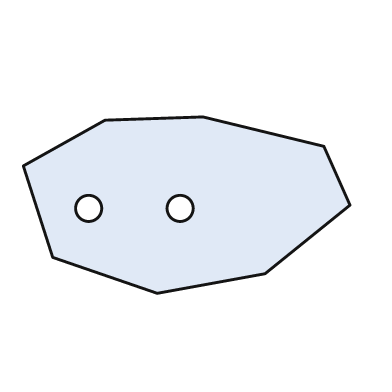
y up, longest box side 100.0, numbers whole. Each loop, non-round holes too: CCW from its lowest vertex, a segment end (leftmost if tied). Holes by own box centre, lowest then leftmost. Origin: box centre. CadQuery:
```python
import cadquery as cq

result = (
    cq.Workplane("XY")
    .moveTo(-9.0, -27.0)
    .lineTo(24.0, -21.0)
    .lineTo(50.0, 0.0)
    .lineTo(42.0, 18.0)
    .lineTo(5.0, 27.0)
    .lineTo(-25.0, 26.0)
    .lineTo(-50.0, 12.0)
    .lineTo(-41.0, -16.0)
    .close()
    .moveTo(-30.0, -1.0)
    .circle(4.0)
    .moveTo(-2.0, -1.0)
    .circle(4.0)
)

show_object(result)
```